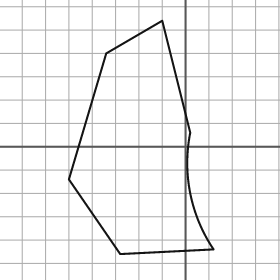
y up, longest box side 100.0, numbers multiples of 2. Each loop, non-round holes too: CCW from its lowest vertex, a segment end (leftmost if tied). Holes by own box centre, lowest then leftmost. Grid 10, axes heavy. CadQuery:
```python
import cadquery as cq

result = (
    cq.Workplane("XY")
    .moveTo(-28.0, -46.0)
    .lineTo(12.0, -44.0)
    .threePointArc((2.0, -20.0), (2.0, 6.0))
    .lineTo(-10.0, 54.0)
    .lineTo(-34.0, 40.0)
    .lineTo(-50.0, -14.0)
    .close()
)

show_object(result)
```